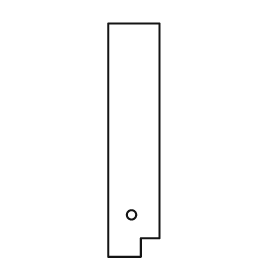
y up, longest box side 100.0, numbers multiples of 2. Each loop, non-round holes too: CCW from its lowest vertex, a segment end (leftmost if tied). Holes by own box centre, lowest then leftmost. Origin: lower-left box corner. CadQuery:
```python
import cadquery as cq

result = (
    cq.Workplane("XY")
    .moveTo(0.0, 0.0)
    .lineTo(14.0, 0.0)
    .lineTo(14.0, 8.0)
    .lineTo(22.0, 8.0)
    .lineTo(22.0, 100.0)
    .lineTo(0.0, 100.0)
    .close()
    .moveTo(10.0, 18.0)
    .circle(2.0)
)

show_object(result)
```